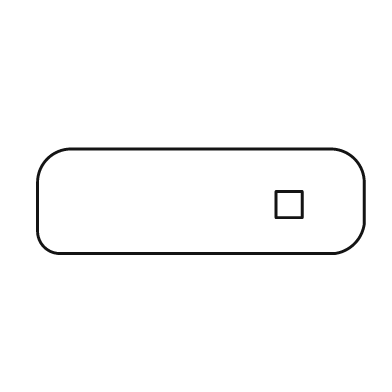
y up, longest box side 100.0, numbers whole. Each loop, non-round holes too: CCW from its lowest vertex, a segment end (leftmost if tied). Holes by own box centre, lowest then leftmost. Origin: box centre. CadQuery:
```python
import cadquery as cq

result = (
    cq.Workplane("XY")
    .moveTo(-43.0, -16.0)
    .lineTo(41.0, -16.0)
    .threePointArc((47.0, -13.0), (50.0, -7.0))
    .lineTo(50.0, 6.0)
    .threePointArc((47.0, 13.0), (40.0, 16.0))
    .lineTo(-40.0, 16.0)
    .threePointArc((-47.0, 13.0), (-50.0, 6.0))
    .lineTo(-50.0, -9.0)
    .threePointArc((-48.0, -14.0), (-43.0, -16.0))
    .close()
    .moveTo(23.0, -5.0)
    .lineTo(31.0, -5.0)
    .lineTo(31.0, 3.0)
    .lineTo(23.0, 3.0)
    .close()
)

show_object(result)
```